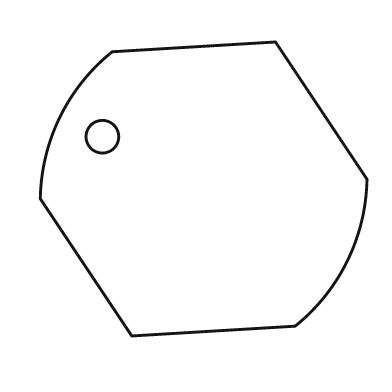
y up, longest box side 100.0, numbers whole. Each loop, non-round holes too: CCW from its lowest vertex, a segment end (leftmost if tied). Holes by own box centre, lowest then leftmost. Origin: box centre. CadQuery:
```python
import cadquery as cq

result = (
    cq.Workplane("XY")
    .moveTo(-22.0, -45.0)
    .lineTo(28.0, -42.0)
    .threePointArc((44.0, -22.0), (50.0, 3.0))
    .lineTo(22.0, 45.0)
    .lineTo(-28.0, 42.0)
    .threePointArc((-44.0, 22.0), (-50.0, -3.0))
    .close()
    .moveTo(-31.0, 16.0)
    .circle(5.0)
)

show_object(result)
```